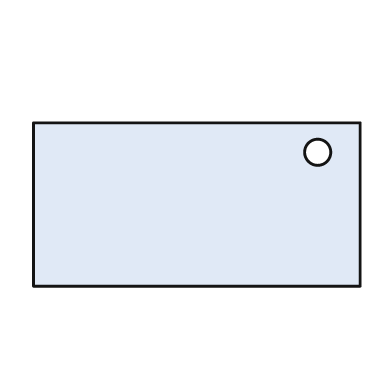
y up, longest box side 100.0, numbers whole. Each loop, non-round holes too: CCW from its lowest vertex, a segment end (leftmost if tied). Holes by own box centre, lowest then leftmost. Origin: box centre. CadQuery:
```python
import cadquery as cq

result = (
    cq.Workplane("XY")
    .moveTo(-50.0, -25.0)
    .lineTo(50.0, -25.0)
    .lineTo(50.0, 25.0)
    .lineTo(-50.0, 25.0)
    .close()
    .moveTo(37.0, 16.0)
    .circle(4.0)
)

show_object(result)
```